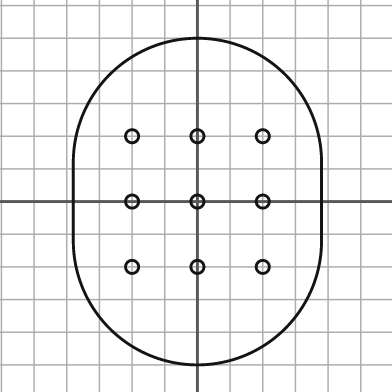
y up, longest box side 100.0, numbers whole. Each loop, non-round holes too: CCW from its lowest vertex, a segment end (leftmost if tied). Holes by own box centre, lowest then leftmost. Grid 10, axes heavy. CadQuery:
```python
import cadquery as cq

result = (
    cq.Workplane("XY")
    .moveTo(-38.0, -12.0)
    .threePointArc((0.0, -50.0), (38.0, -12.0))
    .lineTo(38.0, 12.0)
    .threePointArc((0.0, 50.0), (-38.0, 12.0))
    .close()
    .moveTo(-20.0, -20.0)
    .circle(2.0)
    .moveTo(0.0, -20.0)
    .circle(2.0)
    .moveTo(20.0, -20.0)
    .circle(2.0)
    .moveTo(-20.0, 0.0)
    .circle(2.0)
    .moveTo(0.0, 0.0)
    .circle(2.0)
    .moveTo(20.0, 0.0)
    .circle(2.0)
    .moveTo(-20.0, 20.0)
    .circle(2.0)
    .moveTo(0.0, 20.0)
    .circle(2.0)
    .moveTo(20.0, 20.0)
    .circle(2.0)
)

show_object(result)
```